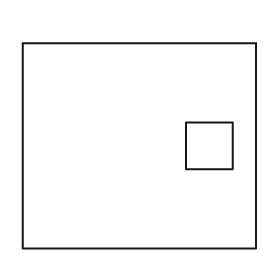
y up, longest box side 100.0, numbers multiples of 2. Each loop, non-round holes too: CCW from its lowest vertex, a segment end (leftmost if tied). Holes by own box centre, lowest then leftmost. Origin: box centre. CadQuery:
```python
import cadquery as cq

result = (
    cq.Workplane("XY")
    .moveTo(-50.0, -44.0)
    .lineTo(50.0, -44.0)
    .lineTo(50.0, 44.0)
    .lineTo(-50.0, 44.0)
    .close()
    .moveTo(20.0, -10.0)
    .lineTo(40.0, -10.0)
    .lineTo(40.0, 10.0)
    .lineTo(20.0, 10.0)
    .close()
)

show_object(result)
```